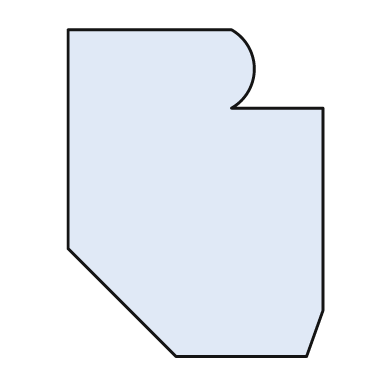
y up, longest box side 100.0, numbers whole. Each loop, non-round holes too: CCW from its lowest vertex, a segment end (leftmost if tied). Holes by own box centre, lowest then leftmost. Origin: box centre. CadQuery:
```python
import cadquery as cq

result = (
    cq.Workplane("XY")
    .moveTo(-6.0, -50.0)
    .lineTo(34.0, -50.0)
    .lineTo(39.0, -36.0)
    .lineTo(39.0, 26.0)
    .lineTo(11.0, 26.0)
    .threePointArc((18.0, 38.0), (11.0, 50.0))
    .lineTo(-39.0, 50.0)
    .lineTo(-39.0, -17.0)
    .close()
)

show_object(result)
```